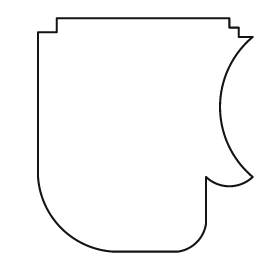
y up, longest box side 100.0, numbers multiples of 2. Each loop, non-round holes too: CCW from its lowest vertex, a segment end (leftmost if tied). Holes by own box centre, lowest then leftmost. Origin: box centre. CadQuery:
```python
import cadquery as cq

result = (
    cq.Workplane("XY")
    .moveTo(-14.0, -50.0)
    .lineTo(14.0, -50.0)
    .threePointArc((22.0, -46.0), (26.0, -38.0))
    .lineTo(26.0, -18.0)
    .threePointArc((36.0, -22.0), (46.0, -18.0))
    .threePointArc((32.0, 12.0), (46.0, 42.0))
    .lineTo(40.0, 42.0)
    .lineTo(40.0, 46.0)
    .lineTo(36.0, 46.0)
    .lineTo(36.0, 50.0)
    .lineTo(-38.0, 50.0)
    .lineTo(-38.0, 44.0)
    .lineTo(-46.0, 44.0)
    .lineTo(-46.0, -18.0)
    .threePointArc((-36.0, -40.0), (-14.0, -50.0))
    .close()
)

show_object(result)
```